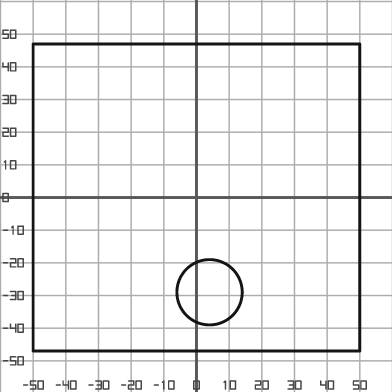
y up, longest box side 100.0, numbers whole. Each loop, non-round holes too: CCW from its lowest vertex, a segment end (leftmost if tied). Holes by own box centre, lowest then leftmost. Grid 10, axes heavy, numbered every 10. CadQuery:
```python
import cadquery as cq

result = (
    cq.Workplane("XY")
    .moveTo(-50.0, -47.0)
    .lineTo(50.0, -47.0)
    .lineTo(50.0, 47.0)
    .lineTo(-50.0, 47.0)
    .close()
    .moveTo(4.0, -29.0)
    .circle(10.0)
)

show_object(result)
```